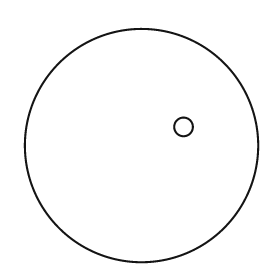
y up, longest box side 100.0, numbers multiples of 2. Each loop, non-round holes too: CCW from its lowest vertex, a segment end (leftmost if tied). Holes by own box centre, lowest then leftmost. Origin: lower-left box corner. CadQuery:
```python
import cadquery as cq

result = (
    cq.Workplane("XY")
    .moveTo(50.0, 50.0)
    .circle(50.0)
    .moveTo(68.0, 58.0)
    .circle(4.0)
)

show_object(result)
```